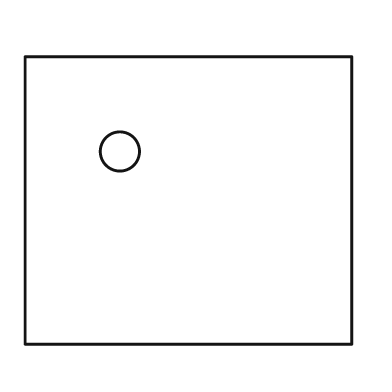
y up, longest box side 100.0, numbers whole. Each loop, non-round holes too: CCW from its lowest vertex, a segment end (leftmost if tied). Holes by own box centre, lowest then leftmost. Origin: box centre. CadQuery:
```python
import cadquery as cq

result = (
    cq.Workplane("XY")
    .moveTo(-50.0, -44.0)
    .lineTo(50.0, -44.0)
    .lineTo(50.0, 44.0)
    .lineTo(-50.0, 44.0)
    .close()
    .moveTo(-21.0, 15.0)
    .circle(6.0)
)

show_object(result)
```